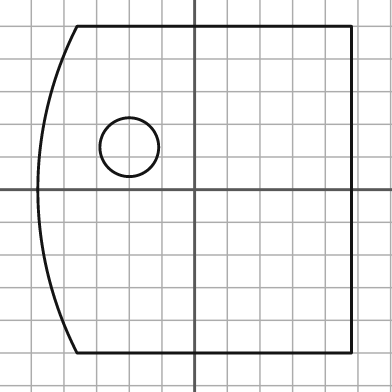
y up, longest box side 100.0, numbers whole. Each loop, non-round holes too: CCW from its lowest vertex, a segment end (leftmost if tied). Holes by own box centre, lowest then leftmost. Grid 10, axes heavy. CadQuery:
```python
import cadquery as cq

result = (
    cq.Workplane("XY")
    .moveTo(-36.0, -50.0)
    .lineTo(48.0, -50.0)
    .lineTo(48.0, 50.0)
    .lineTo(-36.0, 50.0)
    .threePointArc((-48.0, 0.0), (-36.0, -50.0))
    .close()
    .moveTo(-20.0, 13.0)
    .circle(9.0)
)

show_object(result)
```